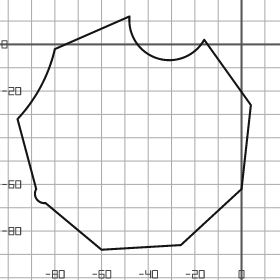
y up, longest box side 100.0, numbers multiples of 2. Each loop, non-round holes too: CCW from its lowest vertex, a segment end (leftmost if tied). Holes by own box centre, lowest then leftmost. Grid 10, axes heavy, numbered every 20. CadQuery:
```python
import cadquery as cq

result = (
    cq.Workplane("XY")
    .moveTo(-60.0, -88.0)
    .lineTo(-26.0, -86.0)
    .lineTo(0.0, -62.0)
    .lineTo(4.0, -26.0)
    .lineTo(-16.0, 2.0)
    .threePointArc((-36.0, -6.0), (-48.0, 12.0))
    .lineTo(-80.0, -2.0)
    .threePointArc((-86.0, -18.0), (-96.0, -32.0))
    .lineTo(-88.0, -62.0)
    .threePointArc((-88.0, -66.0), (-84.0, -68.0))
    .close()
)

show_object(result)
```